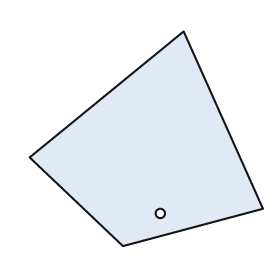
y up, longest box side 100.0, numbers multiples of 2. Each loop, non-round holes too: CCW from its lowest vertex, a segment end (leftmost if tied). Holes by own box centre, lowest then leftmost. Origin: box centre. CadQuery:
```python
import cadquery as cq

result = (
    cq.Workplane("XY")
    .moveTo(-10.0, -46.0)
    .lineTo(50.0, -30.0)
    .lineTo(16.0, 46.0)
    .lineTo(-50.0, -8.0)
    .close()
    .moveTo(6.0, -32.0)
    .circle(2.0)
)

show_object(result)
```